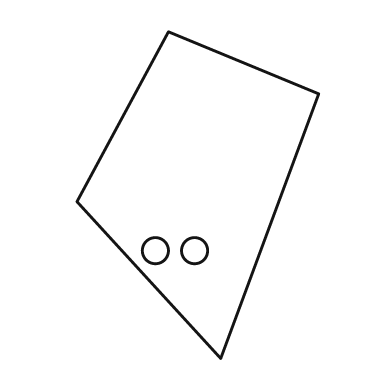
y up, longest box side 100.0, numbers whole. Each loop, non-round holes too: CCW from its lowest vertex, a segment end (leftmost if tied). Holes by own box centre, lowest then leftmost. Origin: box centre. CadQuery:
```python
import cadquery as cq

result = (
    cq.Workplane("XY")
    .moveTo(7.0, -50.0)
    .lineTo(37.0, 31.0)
    .lineTo(-9.0, 50.0)
    .lineTo(-37.0, -2.0)
    .close()
    .moveTo(-13.0, -17.0)
    .circle(4.0)
    .moveTo(-1.0, -17.0)
    .circle(4.0)
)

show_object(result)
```